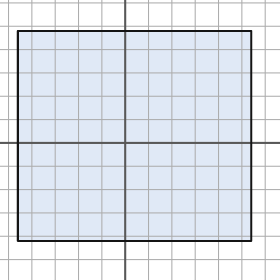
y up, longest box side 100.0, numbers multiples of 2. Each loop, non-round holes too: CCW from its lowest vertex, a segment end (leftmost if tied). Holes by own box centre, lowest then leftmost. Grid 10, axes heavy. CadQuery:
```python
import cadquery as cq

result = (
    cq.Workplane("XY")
    .moveTo(-46.0, -42.0)
    .lineTo(54.0, -42.0)
    .lineTo(54.0, 48.0)
    .lineTo(-46.0, 48.0)
    .close()
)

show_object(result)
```